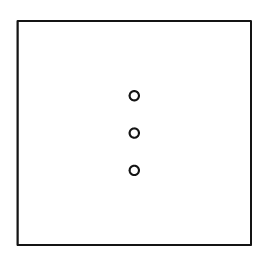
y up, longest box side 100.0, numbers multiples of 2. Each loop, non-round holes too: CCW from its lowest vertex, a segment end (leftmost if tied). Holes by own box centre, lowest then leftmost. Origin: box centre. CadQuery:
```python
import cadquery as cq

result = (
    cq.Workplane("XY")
    .moveTo(-50.0, -48.0)
    .lineTo(50.0, -48.0)
    .lineTo(50.0, 48.0)
    .lineTo(-50.0, 48.0)
    .close()
    .moveTo(0.0, -16.0)
    .circle(2.0)
    .moveTo(0.0, 0.0)
    .circle(2.0)
    .moveTo(0.0, 16.0)
    .circle(2.0)
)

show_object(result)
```